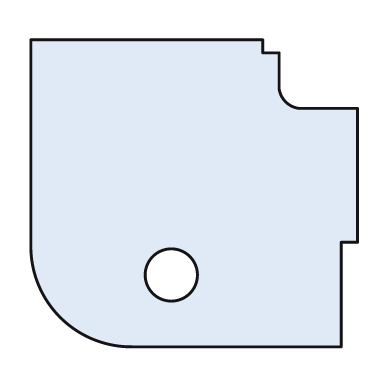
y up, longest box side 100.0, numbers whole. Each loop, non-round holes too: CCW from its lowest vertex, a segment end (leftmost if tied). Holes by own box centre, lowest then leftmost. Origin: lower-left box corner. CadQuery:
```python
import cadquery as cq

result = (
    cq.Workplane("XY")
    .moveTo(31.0, 0.0)
    .lineTo(95.0, 0.0)
    .lineTo(95.0, 32.0)
    .lineTo(100.0, 32.0)
    .lineTo(100.0, 73.0)
    .lineTo(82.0, 73.0)
    .threePointArc((78.0, 75.0), (76.0, 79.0))
    .lineTo(76.0, 90.0)
    .lineTo(71.0, 90.0)
    .lineTo(71.0, 94.0)
    .lineTo(0.0, 94.0)
    .lineTo(0.0, 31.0)
    .threePointArc((9.0, 9.0), (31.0, 0.0))
    .close()
    .moveTo(43.0, 22.0)
    .circle(8.0)
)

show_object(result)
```